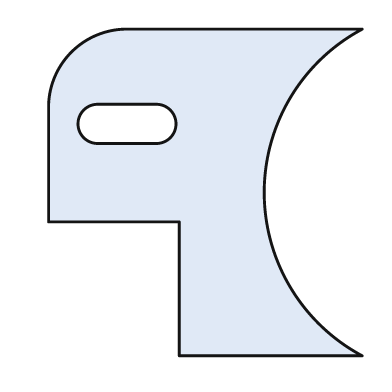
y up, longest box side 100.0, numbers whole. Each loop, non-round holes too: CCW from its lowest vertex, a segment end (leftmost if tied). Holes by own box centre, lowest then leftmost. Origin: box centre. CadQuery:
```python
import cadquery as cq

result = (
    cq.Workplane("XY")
    .moveTo(-8.0, -50.0)
    .lineTo(48.0, -50.0)
    .threePointArc((18.0, 0.0), (48.0, 50.0))
    .lineTo(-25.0, 50.0)
    .threePointArc((-41.0, 43.0), (-48.0, 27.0))
    .lineTo(-48.0, -9.0)
    .lineTo(-8.0, -9.0)
    .close()
    .moveTo(-33.0, 15.0)
    .lineTo(-15.0, 15.0)
    .threePointArc((-9.0, 21.0), (-15.0, 27.0))
    .lineTo(-33.0, 27.0)
    .threePointArc((-39.0, 21.0), (-33.0, 15.0))
    .close()
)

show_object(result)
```